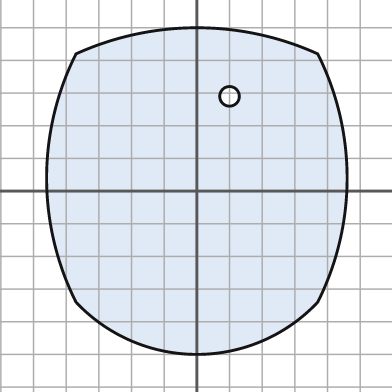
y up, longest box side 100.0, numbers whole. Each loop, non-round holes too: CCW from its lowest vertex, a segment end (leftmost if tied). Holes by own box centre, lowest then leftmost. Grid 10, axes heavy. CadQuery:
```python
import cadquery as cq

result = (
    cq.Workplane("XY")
    .moveTo(-37.0, -34.0)
    .threePointArc((0.0, -50.0), (37.0, -34.0))
    .threePointArc((46.0, 4.0), (37.0, 42.0))
    .threePointArc((0.0, 50.0), (-37.0, 42.0))
    .threePointArc((-46.0, 4.0), (-37.0, -34.0))
    .close()
    .moveTo(10.0, 29.0)
    .circle(3.0)
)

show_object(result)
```